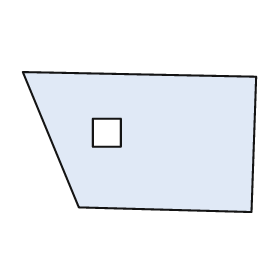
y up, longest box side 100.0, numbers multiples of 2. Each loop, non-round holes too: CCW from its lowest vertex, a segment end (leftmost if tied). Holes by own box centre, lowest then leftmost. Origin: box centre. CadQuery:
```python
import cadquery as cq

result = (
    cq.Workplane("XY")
    .moveTo(48.0, -30.0)
    .lineTo(50.0, 28.0)
    .lineTo(-50.0, 30.0)
    .lineTo(-26.0, -28.0)
    .close()
    .moveTo(-20.0, -2.0)
    .lineTo(-8.0, -2.0)
    .lineTo(-8.0, 10.0)
    .lineTo(-20.0, 10.0)
    .close()
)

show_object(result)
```